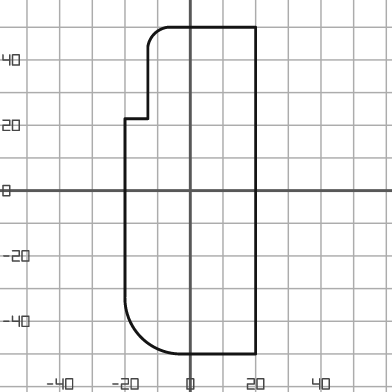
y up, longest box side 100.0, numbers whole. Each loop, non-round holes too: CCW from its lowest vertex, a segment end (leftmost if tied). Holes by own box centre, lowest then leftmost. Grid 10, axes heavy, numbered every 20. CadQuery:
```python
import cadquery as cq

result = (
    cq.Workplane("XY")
    .moveTo(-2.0, -50.0)
    .lineTo(20.0, -50.0)
    .lineTo(20.0, 50.0)
    .lineTo(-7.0, 50.0)
    .threePointArc((-11.0, 48.0), (-13.0, 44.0))
    .lineTo(-13.0, 22.0)
    .lineTo(-20.0, 22.0)
    .lineTo(-20.0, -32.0)
    .threePointArc((-15.0, -45.0), (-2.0, -50.0))
    .close()
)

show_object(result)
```